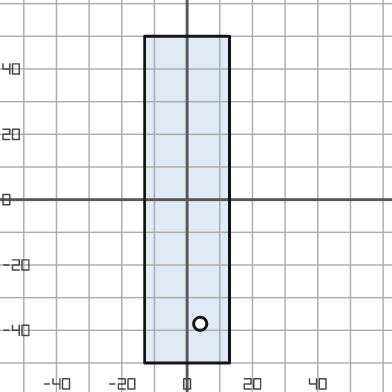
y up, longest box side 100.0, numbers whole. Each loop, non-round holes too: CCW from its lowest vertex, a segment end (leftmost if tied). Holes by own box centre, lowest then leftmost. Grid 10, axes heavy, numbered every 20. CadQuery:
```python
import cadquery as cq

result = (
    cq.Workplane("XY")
    .moveTo(-13.0, -50.0)
    .lineTo(13.0, -50.0)
    .lineTo(13.0, 50.0)
    .lineTo(-13.0, 50.0)
    .close()
    .moveTo(4.0, -38.0)
    .circle(2.0)
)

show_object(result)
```